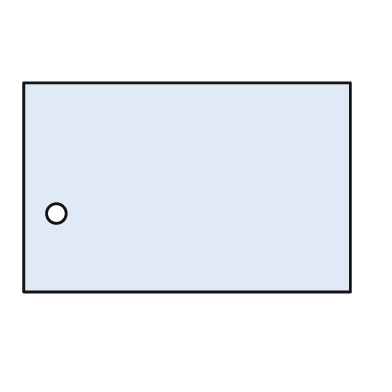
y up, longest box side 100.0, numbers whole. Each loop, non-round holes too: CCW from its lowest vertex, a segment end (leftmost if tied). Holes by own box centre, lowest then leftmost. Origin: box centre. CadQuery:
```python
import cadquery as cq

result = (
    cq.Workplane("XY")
    .moveTo(-50.0, -32.0)
    .lineTo(50.0, -32.0)
    .lineTo(50.0, 32.0)
    .lineTo(-50.0, 32.0)
    .close()
    .moveTo(-40.0, -8.0)
    .circle(3.0)
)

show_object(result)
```